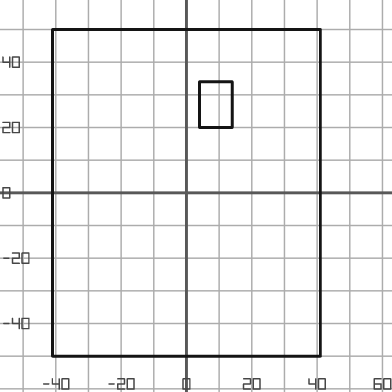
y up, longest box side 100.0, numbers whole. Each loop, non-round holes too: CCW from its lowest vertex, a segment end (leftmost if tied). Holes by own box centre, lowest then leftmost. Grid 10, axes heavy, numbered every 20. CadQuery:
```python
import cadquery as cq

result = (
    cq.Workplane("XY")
    .moveTo(-41.0, -50.0)
    .lineTo(41.0, -50.0)
    .lineTo(41.0, 50.0)
    .lineTo(-41.0, 50.0)
    .close()
    .moveTo(4.0, 20.0)
    .lineTo(14.0, 20.0)
    .lineTo(14.0, 34.0)
    .lineTo(4.0, 34.0)
    .close()
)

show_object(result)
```